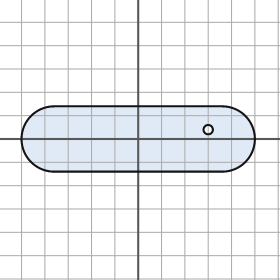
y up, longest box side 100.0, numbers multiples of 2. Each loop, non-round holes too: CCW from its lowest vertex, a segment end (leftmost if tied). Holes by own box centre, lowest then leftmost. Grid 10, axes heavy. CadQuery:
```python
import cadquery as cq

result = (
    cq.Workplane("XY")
    .moveTo(-36.0, -14.0)
    .lineTo(36.0, -14.0)
    .threePointArc((50.0, 0.0), (36.0, 14.0))
    .lineTo(-36.0, 14.0)
    .threePointArc((-50.0, 0.0), (-36.0, -14.0))
    .close()
    .moveTo(30.0, 4.0)
    .circle(2.0)
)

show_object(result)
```